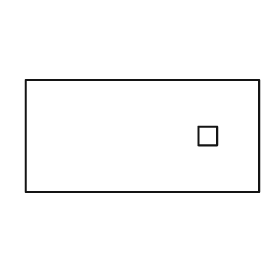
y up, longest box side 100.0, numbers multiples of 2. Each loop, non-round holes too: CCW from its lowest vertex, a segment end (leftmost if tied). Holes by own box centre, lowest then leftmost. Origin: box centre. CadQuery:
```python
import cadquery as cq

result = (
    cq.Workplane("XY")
    .moveTo(-50.0, -24.0)
    .lineTo(50.0, -24.0)
    .lineTo(50.0, 24.0)
    .lineTo(-50.0, 24.0)
    .close()
    .moveTo(24.0, -4.0)
    .lineTo(32.0, -4.0)
    .lineTo(32.0, 4.0)
    .lineTo(24.0, 4.0)
    .close()
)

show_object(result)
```